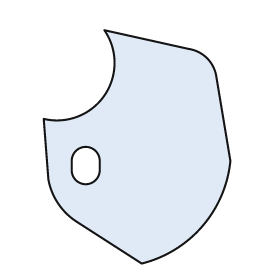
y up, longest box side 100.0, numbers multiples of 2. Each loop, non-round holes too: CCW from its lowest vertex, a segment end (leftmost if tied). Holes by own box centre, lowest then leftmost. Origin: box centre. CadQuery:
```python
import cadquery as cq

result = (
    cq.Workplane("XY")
    .moveTo(2.0, -50.0)
    .threePointArc((28.0, -34.0), (40.0, -6.0))
    .lineTo(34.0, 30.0)
    .threePointArc((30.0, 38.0), (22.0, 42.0))
    .lineTo(-14.0, 50.0)
    .threePointArc((-14.0, 22.0), (-40.0, 12.0))
    .lineTo(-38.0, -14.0)
    .threePointArc((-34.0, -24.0), (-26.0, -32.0))
    .close()
    .moveTo(-28.0, -10.0)
    .threePointArc((-22.0, -16.0), (-16.0, -10.0))
    .lineTo(-16.0, -6.0)
    .threePointArc((-22.0, 0.0), (-28.0, -6.0))
    .close()
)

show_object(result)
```